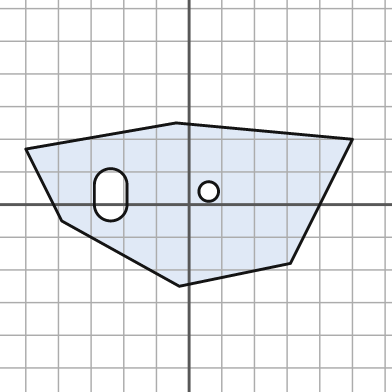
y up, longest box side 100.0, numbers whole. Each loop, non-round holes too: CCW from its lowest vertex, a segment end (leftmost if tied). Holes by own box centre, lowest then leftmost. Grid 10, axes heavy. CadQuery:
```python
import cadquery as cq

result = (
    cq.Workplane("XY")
    .moveTo(-3.0, -25.0)
    .lineTo(31.0, -18.0)
    .lineTo(50.0, 20.0)
    .lineTo(-4.0, 25.0)
    .lineTo(-50.0, 17.0)
    .lineTo(-39.0, -5.0)
    .close()
    .moveTo(-29.0, 0.0)
    .threePointArc((-24.0, -5.0), (-19.0, 0.0))
    .lineTo(-19.0, 6.0)
    .threePointArc((-24.0, 11.0), (-29.0, 6.0))
    .close()
    .moveTo(6.0, 4.0)
    .circle(3.0)
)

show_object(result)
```